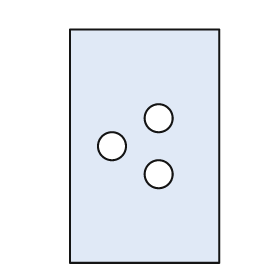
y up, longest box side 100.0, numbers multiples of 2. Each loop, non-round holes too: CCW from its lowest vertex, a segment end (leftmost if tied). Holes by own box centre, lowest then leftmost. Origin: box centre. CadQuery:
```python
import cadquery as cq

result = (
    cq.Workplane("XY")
    .moveTo(-32.0, -50.0)
    .lineTo(32.0, -50.0)
    .lineTo(32.0, 50.0)
    .lineTo(-32.0, 50.0)
    .close()
    .moveTo(6.0, -12.0)
    .circle(6.0)
    .moveTo(-14.0, 0.0)
    .circle(6.0)
    .moveTo(6.0, 12.0)
    .circle(6.0)
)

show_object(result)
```